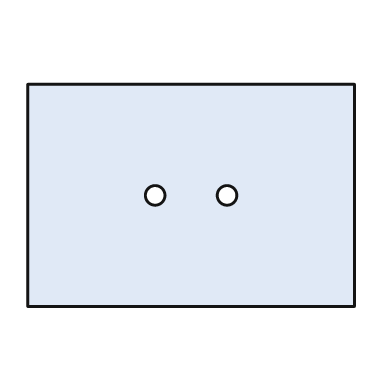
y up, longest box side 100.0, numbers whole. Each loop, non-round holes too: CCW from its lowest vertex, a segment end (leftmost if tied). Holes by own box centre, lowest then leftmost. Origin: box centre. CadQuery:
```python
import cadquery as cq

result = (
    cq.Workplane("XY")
    .moveTo(-50.0, -34.0)
    .lineTo(50.0, -34.0)
    .lineTo(50.0, 34.0)
    .lineTo(-50.0, 34.0)
    .close()
    .moveTo(-11.0, 0.0)
    .circle(3.0)
    .moveTo(11.0, 0.0)
    .circle(3.0)
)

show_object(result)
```